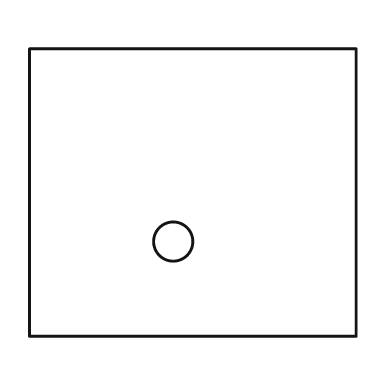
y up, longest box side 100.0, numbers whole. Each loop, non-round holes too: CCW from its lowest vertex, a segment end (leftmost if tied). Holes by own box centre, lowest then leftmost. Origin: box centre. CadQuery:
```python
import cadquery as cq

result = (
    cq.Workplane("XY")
    .moveTo(-50.0, -44.0)
    .lineTo(50.0, -44.0)
    .lineTo(50.0, 44.0)
    .lineTo(-50.0, 44.0)
    .close()
    .moveTo(-6.0, -15.0)
    .circle(6.0)
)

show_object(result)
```